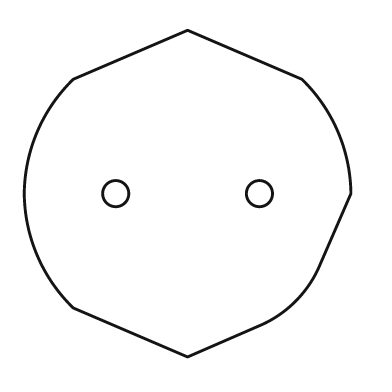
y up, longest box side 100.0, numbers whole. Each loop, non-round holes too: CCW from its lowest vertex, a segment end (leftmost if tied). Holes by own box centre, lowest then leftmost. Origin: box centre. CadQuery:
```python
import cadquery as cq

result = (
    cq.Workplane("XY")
    .moveTo(0.0, -50.0)
    .lineTo(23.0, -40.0)
    .threePointArc((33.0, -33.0), (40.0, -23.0))
    .lineTo(50.0, 0.0)
    .threePointArc((46.0, 19.0), (35.0, 35.0))
    .lineTo(0.0, 50.0)
    .lineTo(-35.0, 35.0)
    .threePointArc((-46.0, 19.0), (-50.0, 0.0))
    .threePointArc((-46.0, -19.0), (-35.0, -35.0))
    .close()
    .moveTo(-22.0, 0.0)
    .circle(4.0)
    .moveTo(22.0, 0.0)
    .circle(4.0)
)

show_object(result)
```